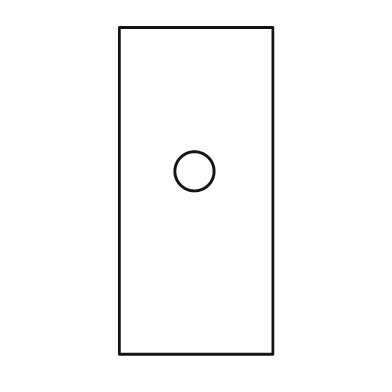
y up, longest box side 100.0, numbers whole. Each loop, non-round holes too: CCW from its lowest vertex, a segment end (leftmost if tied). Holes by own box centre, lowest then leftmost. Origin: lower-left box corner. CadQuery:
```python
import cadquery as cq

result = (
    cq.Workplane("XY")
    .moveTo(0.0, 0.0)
    .lineTo(47.0, 0.0)
    .lineTo(47.0, 100.0)
    .lineTo(0.0, 100.0)
    .close()
    .moveTo(23.0, 56.0)
    .circle(6.0)
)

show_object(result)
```